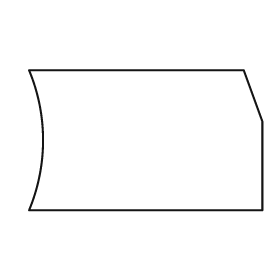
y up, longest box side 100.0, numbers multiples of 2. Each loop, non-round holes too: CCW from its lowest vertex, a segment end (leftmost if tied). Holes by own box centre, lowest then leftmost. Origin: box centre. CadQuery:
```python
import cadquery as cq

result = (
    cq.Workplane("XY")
    .moveTo(-50.0, -30.0)
    .lineTo(50.0, -30.0)
    .lineTo(50.0, 8.0)
    .lineTo(42.0, 30.0)
    .lineTo(-50.0, 30.0)
    .threePointArc((-44.0, 0.0), (-50.0, -30.0))
    .close()
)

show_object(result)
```